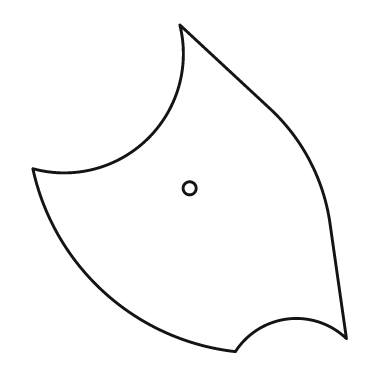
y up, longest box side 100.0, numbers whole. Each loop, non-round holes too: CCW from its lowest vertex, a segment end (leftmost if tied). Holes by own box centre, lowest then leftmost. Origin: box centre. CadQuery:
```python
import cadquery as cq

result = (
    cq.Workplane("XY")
    .moveTo(14.0, -50.0)
    .threePointArc((30.0, -40.0), (48.0, -46.0))
    .lineTo(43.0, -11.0)
    .threePointArc((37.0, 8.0), (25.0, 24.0))
    .lineTo(-3.0, 50.0)
    .threePointArc((-13.0, 15.0), (-48.0, 6.0))
    .threePointArc((-26.0, -32.0), (14.0, -50.0))
    .close()
    .moveTo(0.0, 0.0)
    .circle(2.0)
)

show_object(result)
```